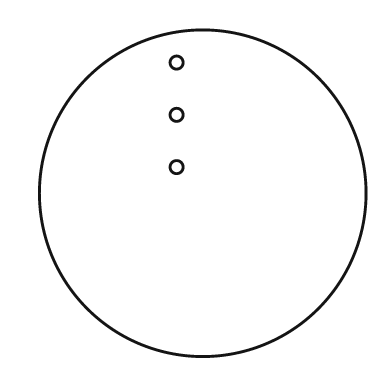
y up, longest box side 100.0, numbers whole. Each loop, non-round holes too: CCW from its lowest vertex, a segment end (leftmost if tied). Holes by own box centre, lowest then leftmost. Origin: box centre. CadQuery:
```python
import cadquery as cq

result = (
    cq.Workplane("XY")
    .moveTo(0.0, 0.0)
    .circle(50.0)
    .moveTo(-8.0, 8.0)
    .circle(2.0)
    .moveTo(-8.0, 24.0)
    .circle(2.0)
    .moveTo(-8.0, 40.0)
    .circle(2.0)
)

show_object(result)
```